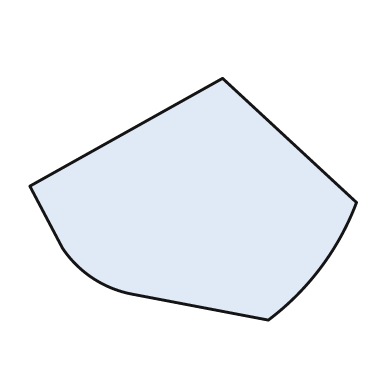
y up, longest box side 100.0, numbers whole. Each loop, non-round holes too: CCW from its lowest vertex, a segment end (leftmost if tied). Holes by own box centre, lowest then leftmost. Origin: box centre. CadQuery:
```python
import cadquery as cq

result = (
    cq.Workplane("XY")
    .moveTo(23.0, -37.0)
    .threePointArc((39.0, -21.0), (50.0, -1.0))
    .lineTo(9.0, 37.0)
    .lineTo(-50.0, 4.0)
    .lineTo(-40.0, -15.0)
    .threePointArc((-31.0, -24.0), (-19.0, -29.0))
    .close()
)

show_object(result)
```